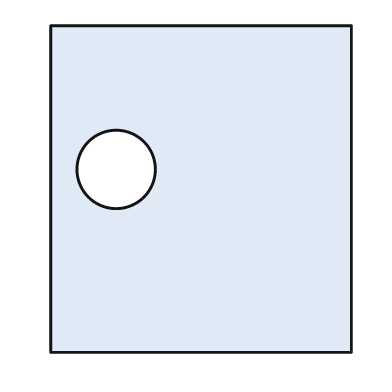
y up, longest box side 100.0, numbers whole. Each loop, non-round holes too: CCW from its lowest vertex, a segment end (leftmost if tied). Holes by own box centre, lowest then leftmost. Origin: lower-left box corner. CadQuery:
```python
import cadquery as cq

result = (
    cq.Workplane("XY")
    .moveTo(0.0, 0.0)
    .lineTo(92.0, 0.0)
    .lineTo(92.0, 100.0)
    .lineTo(0.0, 100.0)
    .close()
    .moveTo(20.0, 56.0)
    .circle(12.0)
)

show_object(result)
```